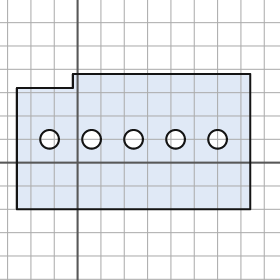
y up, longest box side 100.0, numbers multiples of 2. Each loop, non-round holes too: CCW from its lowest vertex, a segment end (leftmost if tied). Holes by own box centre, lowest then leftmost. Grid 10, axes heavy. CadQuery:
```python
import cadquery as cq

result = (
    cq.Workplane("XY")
    .moveTo(-26.0, -20.0)
    .lineTo(74.0, -20.0)
    .lineTo(74.0, 38.0)
    .lineTo(-2.0, 38.0)
    .lineTo(-2.0, 32.0)
    .lineTo(-26.0, 32.0)
    .close()
    .moveTo(-12.0, 10.0)
    .circle(4.0)
    .moveTo(6.0, 10.0)
    .circle(4.0)
    .moveTo(24.0, 10.0)
    .circle(4.0)
    .moveTo(42.0, 10.0)
    .circle(4.0)
    .moveTo(60.0, 10.0)
    .circle(4.0)
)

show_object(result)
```